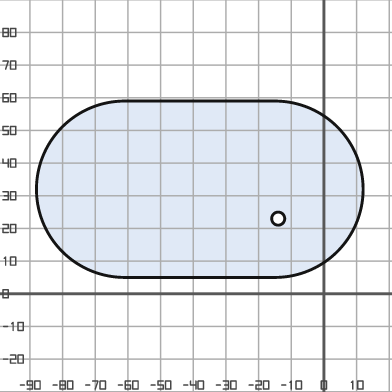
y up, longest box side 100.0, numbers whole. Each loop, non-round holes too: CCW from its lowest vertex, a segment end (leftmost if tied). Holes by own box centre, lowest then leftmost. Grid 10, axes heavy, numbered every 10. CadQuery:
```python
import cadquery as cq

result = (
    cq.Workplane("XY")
    .moveTo(-61.0, 5.0)
    .lineTo(-15.0, 5.0)
    .threePointArc((12.0, 32.0), (-15.0, 59.0))
    .lineTo(-61.0, 59.0)
    .threePointArc((-88.0, 32.0), (-61.0, 5.0))
    .close()
    .moveTo(-14.0, 23.0)
    .circle(2.0)
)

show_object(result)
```